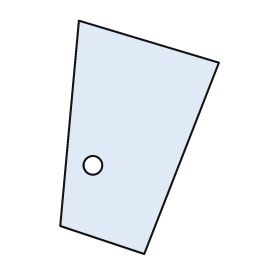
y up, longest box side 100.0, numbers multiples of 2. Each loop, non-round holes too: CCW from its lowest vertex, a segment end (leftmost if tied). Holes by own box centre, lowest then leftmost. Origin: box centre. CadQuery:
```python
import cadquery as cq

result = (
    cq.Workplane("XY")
    .moveTo(2.0, -50.0)
    .lineTo(34.0, 32.0)
    .lineTo(-26.0, 50.0)
    .lineTo(-34.0, -38.0)
    .close()
    .moveTo(-20.0, -12.0)
    .circle(4.0)
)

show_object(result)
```